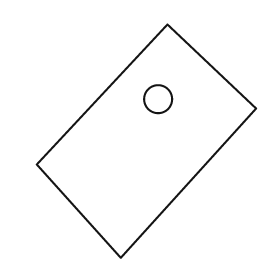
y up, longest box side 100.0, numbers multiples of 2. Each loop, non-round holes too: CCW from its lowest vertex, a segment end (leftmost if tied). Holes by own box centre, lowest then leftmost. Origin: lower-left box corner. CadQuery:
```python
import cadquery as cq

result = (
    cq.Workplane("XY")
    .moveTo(36.0, 0.0)
    .lineTo(94.0, 64.0)
    .lineTo(56.0, 100.0)
    .lineTo(0.0, 40.0)
    .close()
    .moveTo(52.0, 68.0)
    .circle(6.0)
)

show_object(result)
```